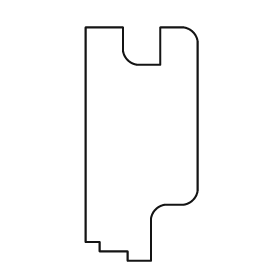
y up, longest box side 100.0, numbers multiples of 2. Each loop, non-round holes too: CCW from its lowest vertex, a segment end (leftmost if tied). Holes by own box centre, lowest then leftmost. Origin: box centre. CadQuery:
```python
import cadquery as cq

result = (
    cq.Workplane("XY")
    .moveTo(-6.0, -50.0)
    .lineTo(4.0, -50.0)
    .lineTo(4.0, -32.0)
    .threePointArc((6.0, -28.0), (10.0, -26.0))
    .lineTo(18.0, -26.0)
    .threePointArc((22.0, -24.0), (24.0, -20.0))
    .lineTo(24.0, 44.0)
    .threePointArc((22.0, 48.0), (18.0, 50.0))
    .lineTo(8.0, 50.0)
    .lineTo(8.0, 34.0)
    .lineTo(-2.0, 34.0)
    .threePointArc((-6.0, 36.0), (-8.0, 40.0))
    .lineTo(-8.0, 50.0)
    .lineTo(-24.0, 50.0)
    .lineTo(-24.0, -42.0)
    .lineTo(-18.0, -42.0)
    .lineTo(-18.0, -46.0)
    .lineTo(-6.0, -46.0)
    .close()
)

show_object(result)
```